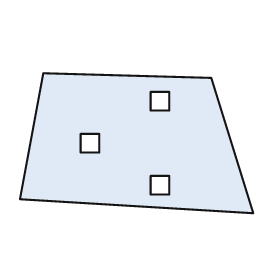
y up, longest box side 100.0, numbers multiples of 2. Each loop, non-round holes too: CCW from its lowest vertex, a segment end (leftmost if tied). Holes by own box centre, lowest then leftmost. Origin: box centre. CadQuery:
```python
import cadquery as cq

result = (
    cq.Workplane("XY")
    .moveTo(50.0, -30.0)
    .lineTo(32.0, 28.0)
    .lineTo(-40.0, 30.0)
    .lineTo(-50.0, -24.0)
    .close()
    .moveTo(6.0, -22.0)
    .lineTo(14.0, -22.0)
    .lineTo(14.0, -14.0)
    .lineTo(6.0, -14.0)
    .close()
    .moveTo(-24.0, -4.0)
    .lineTo(-16.0, -4.0)
    .lineTo(-16.0, 4.0)
    .lineTo(-24.0, 4.0)
    .close()
    .moveTo(6.0, 14.0)
    .lineTo(14.0, 14.0)
    .lineTo(14.0, 22.0)
    .lineTo(6.0, 22.0)
    .close()
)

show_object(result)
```